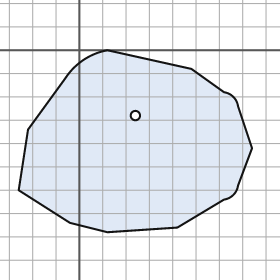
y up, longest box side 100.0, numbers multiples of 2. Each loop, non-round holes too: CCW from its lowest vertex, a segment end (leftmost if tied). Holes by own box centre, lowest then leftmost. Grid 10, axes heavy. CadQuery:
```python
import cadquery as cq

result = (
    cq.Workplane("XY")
    .moveTo(12.0, -78.0)
    .lineTo(42.0, -76.0)
    .lineTo(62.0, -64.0)
    .threePointArc((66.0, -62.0), (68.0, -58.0))
    .lineTo(74.0, -42.0)
    .lineTo(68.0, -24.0)
    .threePointArc((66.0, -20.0), (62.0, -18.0))
    .lineTo(48.0, -8.0)
    .lineTo(12.0, 0.0)
    .threePointArc((2.0, -4.0), (-6.0, -12.0))
    .lineTo(-22.0, -34.0)
    .lineTo(-26.0, -60.0)
    .lineTo(-4.0, -74.0)
    .close()
    .moveTo(24.0, -28.0)
    .circle(2.0)
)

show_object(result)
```